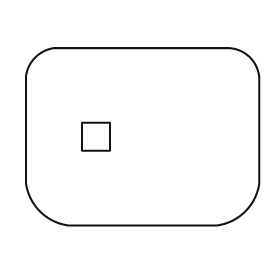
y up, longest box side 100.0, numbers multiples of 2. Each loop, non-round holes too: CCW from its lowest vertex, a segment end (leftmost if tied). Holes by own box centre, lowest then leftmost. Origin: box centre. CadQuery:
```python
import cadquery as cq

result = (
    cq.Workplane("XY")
    .moveTo(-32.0, -38.0)
    .lineTo(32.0, -38.0)
    .threePointArc((44.0, -32.0), (50.0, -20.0))
    .lineTo(50.0, 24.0)
    .threePointArc((46.0, 34.0), (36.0, 38.0))
    .lineTo(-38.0, 38.0)
    .threePointArc((-46.0, 34.0), (-50.0, 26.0))
    .lineTo(-50.0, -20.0)
    .threePointArc((-44.0, -32.0), (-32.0, -38.0))
    .close()
    .moveTo(-26.0, -6.0)
    .lineTo(-14.0, -6.0)
    .lineTo(-14.0, 6.0)
    .lineTo(-26.0, 6.0)
    .close()
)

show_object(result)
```